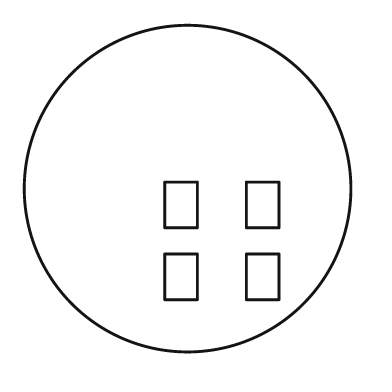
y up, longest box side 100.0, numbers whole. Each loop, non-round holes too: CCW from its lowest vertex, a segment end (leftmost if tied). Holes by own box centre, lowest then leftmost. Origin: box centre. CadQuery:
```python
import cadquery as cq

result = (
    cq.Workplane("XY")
    .moveTo(0.0, 0.0)
    .circle(50.0)
    .moveTo(-7.0, -34.0)
    .lineTo(3.0, -34.0)
    .lineTo(3.0, -20.0)
    .lineTo(-7.0, -20.0)
    .close()
    .moveTo(18.0, -34.0)
    .lineTo(28.0, -34.0)
    .lineTo(28.0, -20.0)
    .lineTo(18.0, -20.0)
    .close()
    .moveTo(-7.0, -12.0)
    .lineTo(3.0, -12.0)
    .lineTo(3.0, 2.0)
    .lineTo(-7.0, 2.0)
    .close()
    .moveTo(18.0, -12.0)
    .lineTo(28.0, -12.0)
    .lineTo(28.0, 2.0)
    .lineTo(18.0, 2.0)
    .close()
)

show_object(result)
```